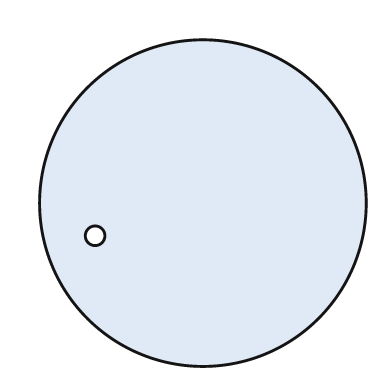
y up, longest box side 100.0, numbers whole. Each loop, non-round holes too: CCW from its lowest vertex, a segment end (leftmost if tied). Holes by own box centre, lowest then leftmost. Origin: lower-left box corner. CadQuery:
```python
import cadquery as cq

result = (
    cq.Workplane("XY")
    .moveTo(50.0, 50.0)
    .circle(50.0)
    .moveTo(17.0, 40.0)
    .circle(3.0)
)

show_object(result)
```